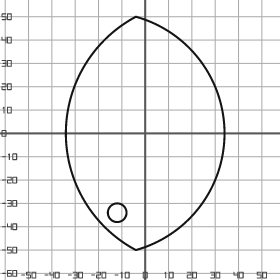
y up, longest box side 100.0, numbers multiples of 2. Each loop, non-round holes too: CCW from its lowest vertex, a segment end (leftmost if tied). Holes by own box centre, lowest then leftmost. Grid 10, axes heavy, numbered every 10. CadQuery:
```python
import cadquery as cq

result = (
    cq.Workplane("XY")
    .moveTo(-4.0, -50.0)
    .threePointArc((34.0, 0.0), (-4.0, 50.0))
    .threePointArc((-34.0, 0.0), (-4.0, -50.0))
    .close()
    .moveTo(-12.0, -34.0)
    .circle(4.0)
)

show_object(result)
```